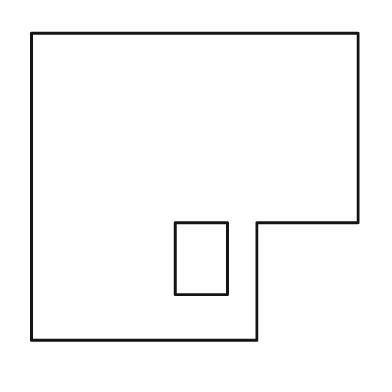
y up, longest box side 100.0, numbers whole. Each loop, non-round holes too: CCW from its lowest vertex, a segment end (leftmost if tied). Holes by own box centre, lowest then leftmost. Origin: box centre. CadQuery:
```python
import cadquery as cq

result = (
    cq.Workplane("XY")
    .moveTo(-50.0, -47.0)
    .lineTo(19.0, -47.0)
    .lineTo(19.0, -11.0)
    .lineTo(50.0, -11.0)
    .lineTo(50.0, 47.0)
    .lineTo(-50.0, 47.0)
    .close()
    .moveTo(-6.0, -33.0)
    .lineTo(10.0, -33.0)
    .lineTo(10.0, -11.0)
    .lineTo(-6.0, -11.0)
    .close()
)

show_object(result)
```